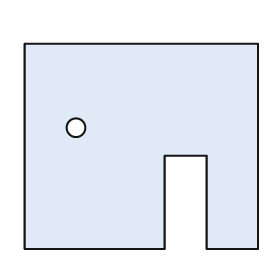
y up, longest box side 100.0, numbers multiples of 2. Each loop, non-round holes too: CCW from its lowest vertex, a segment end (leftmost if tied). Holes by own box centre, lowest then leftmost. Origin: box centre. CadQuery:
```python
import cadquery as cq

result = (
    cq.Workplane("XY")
    .moveTo(-50.0, -44.0)
    .lineTo(10.0, -44.0)
    .lineTo(10.0, -4.0)
    .lineTo(28.0, -4.0)
    .lineTo(28.0, -44.0)
    .lineTo(50.0, -44.0)
    .lineTo(50.0, 44.0)
    .lineTo(-50.0, 44.0)
    .close()
    .moveTo(-28.0, 8.0)
    .circle(4.0)
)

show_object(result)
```